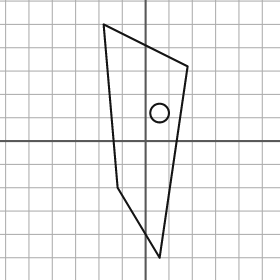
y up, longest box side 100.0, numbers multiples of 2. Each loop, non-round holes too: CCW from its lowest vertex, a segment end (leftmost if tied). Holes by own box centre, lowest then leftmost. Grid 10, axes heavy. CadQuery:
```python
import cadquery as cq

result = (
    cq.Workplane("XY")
    .moveTo(6.0, -50.0)
    .lineTo(18.0, 32.0)
    .lineTo(-18.0, 50.0)
    .lineTo(-12.0, -20.0)
    .close()
    .moveTo(6.0, 12.0)
    .circle(4.0)
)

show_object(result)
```